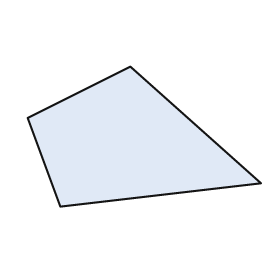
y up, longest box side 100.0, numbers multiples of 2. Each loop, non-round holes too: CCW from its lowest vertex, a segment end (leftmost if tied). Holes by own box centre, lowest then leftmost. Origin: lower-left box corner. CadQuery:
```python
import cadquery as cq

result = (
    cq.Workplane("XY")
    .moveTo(14.0, 0.0)
    .lineTo(100.0, 10.0)
    .lineTo(44.0, 60.0)
    .lineTo(0.0, 38.0)
    .close()
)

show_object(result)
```